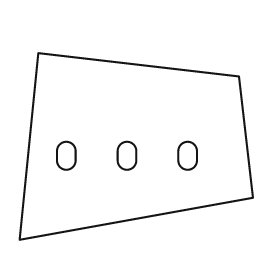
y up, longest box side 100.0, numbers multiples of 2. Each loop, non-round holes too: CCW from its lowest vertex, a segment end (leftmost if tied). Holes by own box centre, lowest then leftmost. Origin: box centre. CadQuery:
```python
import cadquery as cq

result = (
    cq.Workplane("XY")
    .moveTo(-50.0, -40.0)
    .lineTo(50.0, -22.0)
    .lineTo(44.0, 30.0)
    .lineTo(-42.0, 40.0)
    .close()
    .moveTo(-34.0, -6.0)
    .threePointArc((-30.0, -10.0), (-26.0, -6.0))
    .lineTo(-26.0, -2.0)
    .threePointArc((-30.0, 2.0), (-34.0, -2.0))
    .close()
    .moveTo(-8.0, -6.0)
    .threePointArc((-4.0, -10.0), (0.0, -6.0))
    .lineTo(0.0, -2.0)
    .threePointArc((-4.0, 2.0), (-8.0, -2.0))
    .close()
    .moveTo(18.0, -6.0)
    .threePointArc((22.0, -10.0), (26.0, -6.0))
    .lineTo(26.0, -2.0)
    .threePointArc((22.0, 2.0), (18.0, -2.0))
    .close()
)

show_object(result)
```